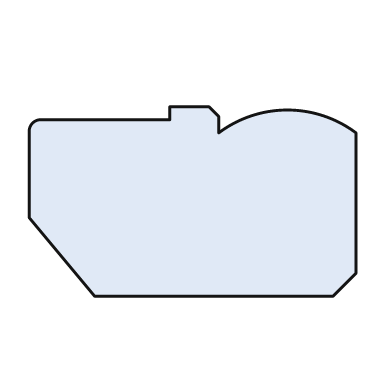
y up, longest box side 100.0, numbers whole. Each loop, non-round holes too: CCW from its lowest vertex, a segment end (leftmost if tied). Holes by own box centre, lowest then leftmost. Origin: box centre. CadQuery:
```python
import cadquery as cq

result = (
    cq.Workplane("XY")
    .moveTo(-30.0, -29.0)
    .lineTo(43.0, -29.0)
    .lineTo(50.0, -22.0)
    .lineTo(50.0, 21.0)
    .threePointArc((29.0, 28.0), (8.0, 21.0))
    .lineTo(8.0, 26.0)
    .lineTo(5.0, 29.0)
    .lineTo(-7.0, 29.0)
    .lineTo(-7.0, 25.0)
    .lineTo(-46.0, 25.0)
    .threePointArc((-49.0, 24.0), (-50.0, 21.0))
    .lineTo(-50.0, -5.0)
    .close()
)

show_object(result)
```